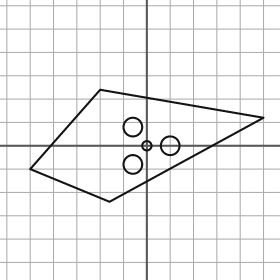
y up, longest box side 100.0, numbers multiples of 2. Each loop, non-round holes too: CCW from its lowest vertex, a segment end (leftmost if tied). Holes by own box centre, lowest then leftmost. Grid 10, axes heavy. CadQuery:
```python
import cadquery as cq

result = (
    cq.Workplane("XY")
    .moveTo(-16.0, -24.0)
    .lineTo(50.0, 12.0)
    .lineTo(-20.0, 24.0)
    .lineTo(-50.0, -10.0)
    .close()
    .moveTo(-6.0, -8.0)
    .circle(4.0)
    .moveTo(0.0, 0.0)
    .circle(2.0)
    .moveTo(10.0, 0.0)
    .circle(4.0)
    .moveTo(-6.0, 8.0)
    .circle(4.0)
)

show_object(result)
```